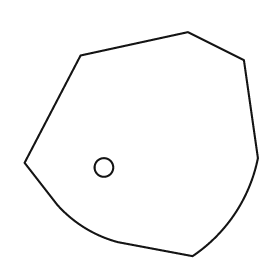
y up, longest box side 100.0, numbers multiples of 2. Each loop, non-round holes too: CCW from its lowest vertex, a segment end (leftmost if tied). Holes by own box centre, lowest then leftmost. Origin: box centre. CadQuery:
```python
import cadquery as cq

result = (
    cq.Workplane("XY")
    .moveTo(22.0, -48.0)
    .threePointArc((40.0, -30.0), (50.0, -6.0))
    .lineTo(44.0, 36.0)
    .lineTo(20.0, 48.0)
    .lineTo(-26.0, 38.0)
    .lineTo(-50.0, -8.0)
    .lineTo(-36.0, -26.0)
    .threePointArc((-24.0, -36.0), (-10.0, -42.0))
    .close()
    .moveTo(-16.0, -10.0)
    .circle(4.0)
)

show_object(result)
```